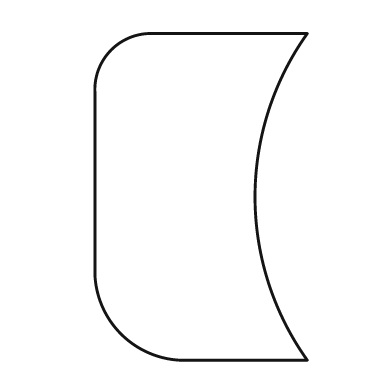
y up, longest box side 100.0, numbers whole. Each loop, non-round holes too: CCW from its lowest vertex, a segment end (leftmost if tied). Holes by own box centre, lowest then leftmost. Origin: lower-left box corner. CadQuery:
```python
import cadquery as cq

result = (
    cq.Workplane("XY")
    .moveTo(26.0, 0.0)
    .lineTo(65.0, 0.0)
    .threePointArc((49.0, 50.0), (65.0, 100.0))
    .lineTo(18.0, 100.0)
    .threePointArc((5.0, 95.0), (0.0, 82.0))
    .lineTo(0.0, 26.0)
    .threePointArc((8.0, 8.0), (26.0, 0.0))
    .close()
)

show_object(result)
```